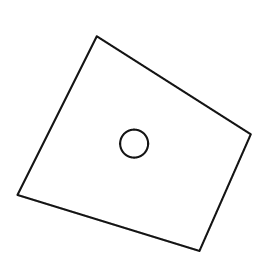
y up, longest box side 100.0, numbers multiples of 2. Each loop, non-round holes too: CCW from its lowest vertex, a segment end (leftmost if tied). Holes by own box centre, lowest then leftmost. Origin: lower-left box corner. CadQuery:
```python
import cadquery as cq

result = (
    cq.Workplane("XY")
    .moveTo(78.0, 0.0)
    .lineTo(100.0, 50.0)
    .lineTo(34.0, 92.0)
    .lineTo(0.0, 24.0)
    .close()
    .moveTo(50.0, 46.0)
    .circle(6.0)
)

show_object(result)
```